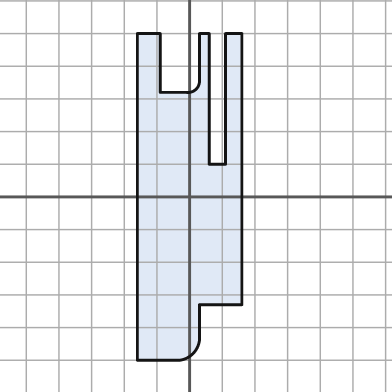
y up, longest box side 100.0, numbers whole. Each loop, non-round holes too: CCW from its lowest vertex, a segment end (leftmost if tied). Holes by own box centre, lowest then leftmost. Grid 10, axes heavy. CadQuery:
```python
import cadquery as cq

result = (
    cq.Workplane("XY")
    .moveTo(-16.0, -50.0)
    .lineTo(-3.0, -50.0)
    .threePointArc((1.0, -48.0), (3.0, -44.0))
    .lineTo(3.0, -33.0)
    .lineTo(16.0, -33.0)
    .lineTo(16.0, 50.0)
    .lineTo(11.0, 50.0)
    .lineTo(11.0, 10.0)
    .lineTo(6.0, 10.0)
    .lineTo(6.0, 50.0)
    .lineTo(3.0, 50.0)
    .lineTo(3.0, 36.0)
    .threePointArc((2.0, 33.0), (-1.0, 32.0))
    .lineTo(-9.0, 32.0)
    .lineTo(-9.0, 50.0)
    .lineTo(-16.0, 50.0)
    .close()
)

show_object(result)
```